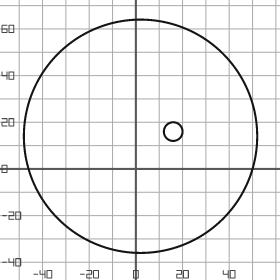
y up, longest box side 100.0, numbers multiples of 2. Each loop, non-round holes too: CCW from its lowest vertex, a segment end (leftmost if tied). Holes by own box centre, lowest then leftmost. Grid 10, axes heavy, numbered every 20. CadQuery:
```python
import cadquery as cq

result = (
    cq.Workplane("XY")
    .moveTo(2.0, 14.0)
    .circle(50.0)
    .moveTo(16.0, 16.0)
    .circle(4.0)
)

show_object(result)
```